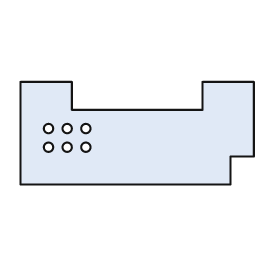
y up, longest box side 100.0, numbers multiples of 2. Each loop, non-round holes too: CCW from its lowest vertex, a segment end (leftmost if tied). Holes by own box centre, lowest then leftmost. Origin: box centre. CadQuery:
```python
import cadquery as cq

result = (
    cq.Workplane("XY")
    .moveTo(-50.0, -22.0)
    .lineTo(40.0, -22.0)
    .lineTo(40.0, -10.0)
    .lineTo(50.0, -10.0)
    .lineTo(50.0, 22.0)
    .lineTo(28.0, 22.0)
    .lineTo(28.0, 10.0)
    .lineTo(-28.0, 10.0)
    .lineTo(-28.0, 22.0)
    .lineTo(-50.0, 22.0)
    .close()
    .moveTo(-38.0, -6.0)
    .circle(2.0)
    .moveTo(-30.0, -6.0)
    .circle(2.0)
    .moveTo(-22.0, -6.0)
    .circle(2.0)
    .moveTo(-38.0, 2.0)
    .circle(2.0)
    .moveTo(-30.0, 2.0)
    .circle(2.0)
    .moveTo(-22.0, 2.0)
    .circle(2.0)
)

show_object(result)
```